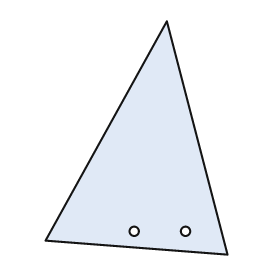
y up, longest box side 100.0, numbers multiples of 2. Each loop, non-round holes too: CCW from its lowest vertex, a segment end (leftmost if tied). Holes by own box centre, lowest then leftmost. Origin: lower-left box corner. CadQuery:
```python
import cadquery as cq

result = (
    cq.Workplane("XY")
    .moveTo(78.0, 0.0)
    .lineTo(52.0, 100.0)
    .lineTo(0.0, 6.0)
    .close()
    .moveTo(38.0, 10.0)
    .circle(2.0)
    .moveTo(60.0, 10.0)
    .circle(2.0)
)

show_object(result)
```